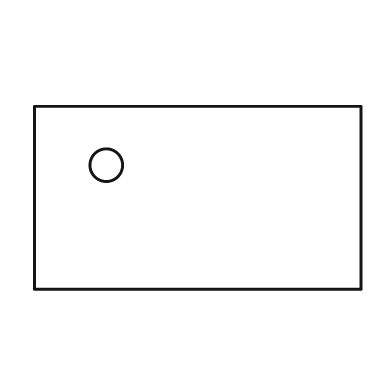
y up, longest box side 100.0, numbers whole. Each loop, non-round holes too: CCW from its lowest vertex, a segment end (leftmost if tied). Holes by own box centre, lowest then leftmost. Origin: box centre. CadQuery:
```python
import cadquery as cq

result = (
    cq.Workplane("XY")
    .moveTo(-50.0, -28.0)
    .lineTo(50.0, -28.0)
    .lineTo(50.0, 28.0)
    .lineTo(-50.0, 28.0)
    .close()
    .moveTo(-28.0, 10.0)
    .circle(5.0)
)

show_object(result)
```